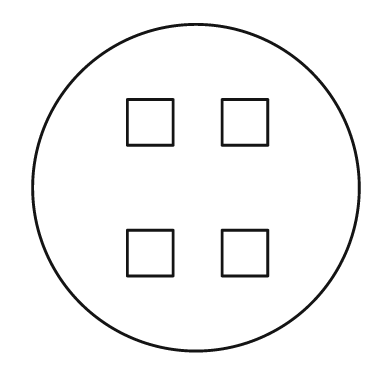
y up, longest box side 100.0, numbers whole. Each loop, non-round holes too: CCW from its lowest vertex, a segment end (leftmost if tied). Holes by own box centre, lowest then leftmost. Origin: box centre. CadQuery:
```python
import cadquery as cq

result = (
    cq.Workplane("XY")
    .moveTo(0.0, 0.0)
    .circle(50.0)
    .moveTo(-21.0, -27.0)
    .lineTo(-7.0, -27.0)
    .lineTo(-7.0, -13.0)
    .lineTo(-21.0, -13.0)
    .close()
    .moveTo(8.0, -27.0)
    .lineTo(22.0, -27.0)
    .lineTo(22.0, -13.0)
    .lineTo(8.0, -13.0)
    .close()
    .moveTo(-21.0, 13.0)
    .lineTo(-7.0, 13.0)
    .lineTo(-7.0, 27.0)
    .lineTo(-21.0, 27.0)
    .close()
    .moveTo(8.0, 13.0)
    .lineTo(22.0, 13.0)
    .lineTo(22.0, 27.0)
    .lineTo(8.0, 27.0)
    .close()
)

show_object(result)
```